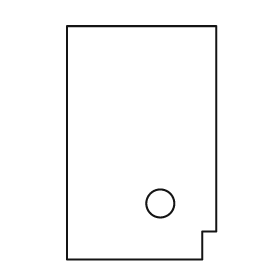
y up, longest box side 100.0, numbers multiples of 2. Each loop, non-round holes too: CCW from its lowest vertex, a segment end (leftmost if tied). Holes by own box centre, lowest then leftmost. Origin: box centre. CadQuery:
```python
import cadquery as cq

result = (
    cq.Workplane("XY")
    .moveTo(-32.0, -50.0)
    .lineTo(26.0, -50.0)
    .lineTo(26.0, -38.0)
    .lineTo(32.0, -38.0)
    .lineTo(32.0, 50.0)
    .lineTo(-32.0, 50.0)
    .close()
    .moveTo(8.0, -26.0)
    .circle(6.0)
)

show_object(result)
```